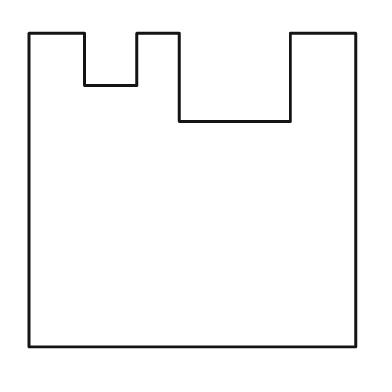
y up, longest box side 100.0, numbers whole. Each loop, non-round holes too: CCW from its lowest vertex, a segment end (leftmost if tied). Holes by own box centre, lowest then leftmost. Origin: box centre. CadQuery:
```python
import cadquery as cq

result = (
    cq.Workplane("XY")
    .moveTo(-50.0, -48.0)
    .lineTo(50.0, -48.0)
    .lineTo(50.0, 48.0)
    .lineTo(30.0, 48.0)
    .lineTo(30.0, 21.0)
    .lineTo(-4.0, 21.0)
    .lineTo(-4.0, 48.0)
    .lineTo(-17.0, 48.0)
    .lineTo(-17.0, 32.0)
    .lineTo(-33.0, 32.0)
    .lineTo(-33.0, 48.0)
    .lineTo(-50.0, 48.0)
    .close()
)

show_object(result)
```